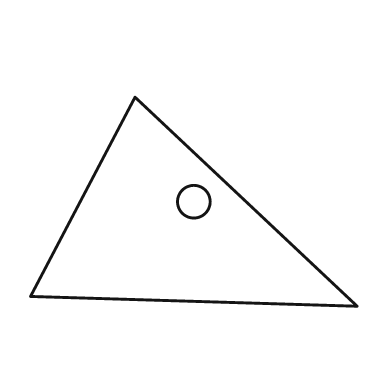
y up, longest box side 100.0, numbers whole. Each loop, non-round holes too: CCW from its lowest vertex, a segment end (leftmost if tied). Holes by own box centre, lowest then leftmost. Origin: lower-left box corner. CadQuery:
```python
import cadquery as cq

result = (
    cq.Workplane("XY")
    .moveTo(100.0, 0.0)
    .lineTo(32.0, 64.0)
    .lineTo(0.0, 3.0)
    .close()
    .moveTo(50.0, 32.0)
    .circle(5.0)
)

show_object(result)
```